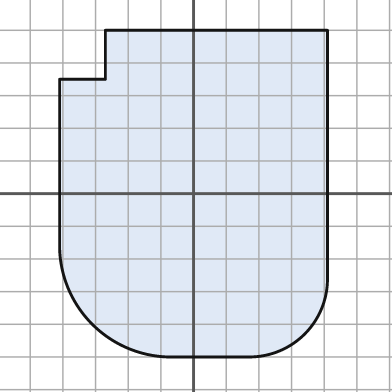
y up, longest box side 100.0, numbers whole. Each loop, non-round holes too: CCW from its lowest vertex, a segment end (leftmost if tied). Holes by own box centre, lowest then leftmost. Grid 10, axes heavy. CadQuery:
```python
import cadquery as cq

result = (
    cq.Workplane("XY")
    .moveTo(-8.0, -50.0)
    .lineTo(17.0, -50.0)
    .threePointArc((34.0, -43.0), (41.0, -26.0))
    .lineTo(41.0, 50.0)
    .lineTo(-27.0, 50.0)
    .lineTo(-27.0, 35.0)
    .lineTo(-41.0, 35.0)
    .lineTo(-41.0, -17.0)
    .threePointArc((-31.0, -40.0), (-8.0, -50.0))
    .close()
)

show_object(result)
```